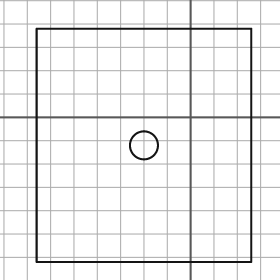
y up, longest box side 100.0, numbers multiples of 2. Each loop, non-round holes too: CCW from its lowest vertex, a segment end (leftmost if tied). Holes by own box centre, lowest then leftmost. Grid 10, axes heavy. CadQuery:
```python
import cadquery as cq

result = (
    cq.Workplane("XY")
    .moveTo(-66.0, -62.0)
    .lineTo(26.0, -62.0)
    .lineTo(26.0, 38.0)
    .lineTo(-66.0, 38.0)
    .close()
    .moveTo(-20.0, -12.0)
    .circle(6.0)
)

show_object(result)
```